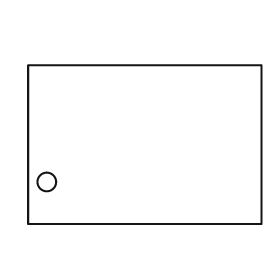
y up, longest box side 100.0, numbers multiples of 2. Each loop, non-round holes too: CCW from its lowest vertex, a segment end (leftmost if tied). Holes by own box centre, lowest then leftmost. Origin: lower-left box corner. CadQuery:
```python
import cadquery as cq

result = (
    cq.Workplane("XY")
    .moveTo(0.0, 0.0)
    .lineTo(100.0, 0.0)
    .lineTo(100.0, 68.0)
    .lineTo(0.0, 68.0)
    .close()
    .moveTo(8.0, 18.0)
    .circle(4.0)
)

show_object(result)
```